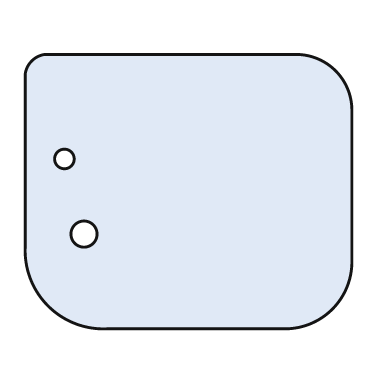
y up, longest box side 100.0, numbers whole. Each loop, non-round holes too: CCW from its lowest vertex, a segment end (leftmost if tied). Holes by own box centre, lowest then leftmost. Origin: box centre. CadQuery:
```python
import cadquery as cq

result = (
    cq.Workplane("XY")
    .moveTo(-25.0, -42.0)
    .lineTo(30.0, -42.0)
    .threePointArc((44.0, -36.0), (50.0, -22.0))
    .lineTo(50.0, 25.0)
    .threePointArc((45.0, 37.0), (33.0, 42.0))
    .lineTo(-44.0, 42.0)
    .threePointArc((-48.0, 40.0), (-50.0, 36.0))
    .lineTo(-50.0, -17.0)
    .threePointArc((-43.0, -35.0), (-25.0, -42.0))
    .close()
    .moveTo(-32.0, -13.0)
    .circle(4.0)
    .moveTo(-38.0, 10.0)
    .circle(3.0)
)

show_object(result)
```